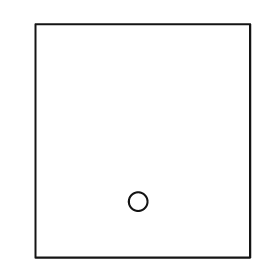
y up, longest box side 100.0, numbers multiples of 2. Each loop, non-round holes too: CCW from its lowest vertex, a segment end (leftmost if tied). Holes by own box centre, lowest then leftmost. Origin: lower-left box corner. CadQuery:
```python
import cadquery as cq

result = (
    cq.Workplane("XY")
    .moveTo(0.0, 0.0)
    .lineTo(92.0, 0.0)
    .lineTo(92.0, 100.0)
    .lineTo(0.0, 100.0)
    .close()
    .moveTo(44.0, 24.0)
    .circle(4.0)
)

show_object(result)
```